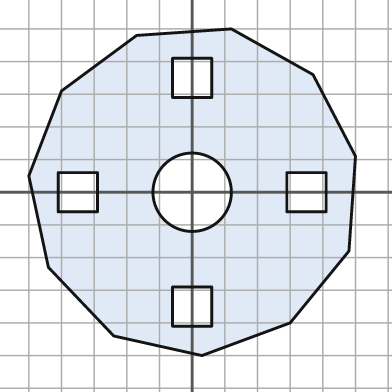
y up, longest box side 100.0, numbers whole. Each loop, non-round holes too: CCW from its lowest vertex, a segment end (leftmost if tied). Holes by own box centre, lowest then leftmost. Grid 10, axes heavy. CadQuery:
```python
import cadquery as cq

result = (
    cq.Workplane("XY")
    .moveTo(3.0, -50.0)
    .lineTo(30.0, -40.0)
    .lineTo(48.0, -18.0)
    .lineTo(50.0, 11.0)
    .lineTo(37.0, 36.0)
    .lineTo(12.0, 50.0)
    .lineTo(-17.0, 48.0)
    .lineTo(-40.0, 31.0)
    .lineTo(-50.0, 5.0)
    .lineTo(-44.0, -23.0)
    .lineTo(-24.0, -44.0)
    .close()
    .moveTo(-6.0, -41.0)
    .lineTo(6.0, -41.0)
    .lineTo(6.0, -29.0)
    .lineTo(-6.0, -29.0)
    .close()
    .moveTo(-41.0, -6.0)
    .lineTo(-29.0, -6.0)
    .lineTo(-29.0, 6.0)
    .lineTo(-41.0, 6.0)
    .close()
    .moveTo(0.0, 0.0)
    .circle(12.0)
    .moveTo(29.0, -6.0)
    .lineTo(41.0, -6.0)
    .lineTo(41.0, 6.0)
    .lineTo(29.0, 6.0)
    .close()
    .moveTo(-6.0, 29.0)
    .lineTo(6.0, 29.0)
    .lineTo(6.0, 41.0)
    .lineTo(-6.0, 41.0)
    .close()
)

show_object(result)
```